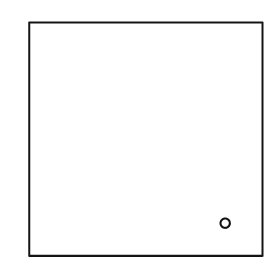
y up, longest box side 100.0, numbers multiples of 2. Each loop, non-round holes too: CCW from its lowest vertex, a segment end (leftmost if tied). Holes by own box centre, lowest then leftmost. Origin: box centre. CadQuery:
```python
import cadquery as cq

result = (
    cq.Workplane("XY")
    .moveTo(-50.0, -50.0)
    .lineTo(50.0, -50.0)
    .lineTo(50.0, 50.0)
    .lineTo(-50.0, 50.0)
    .close()
    .moveTo(34.0, -36.0)
    .circle(2.0)
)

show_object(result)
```